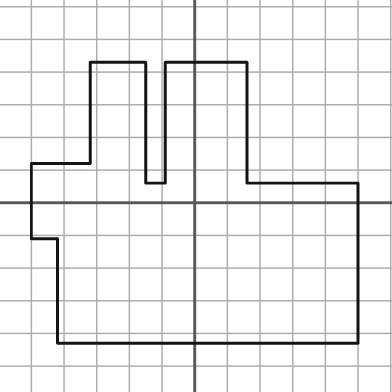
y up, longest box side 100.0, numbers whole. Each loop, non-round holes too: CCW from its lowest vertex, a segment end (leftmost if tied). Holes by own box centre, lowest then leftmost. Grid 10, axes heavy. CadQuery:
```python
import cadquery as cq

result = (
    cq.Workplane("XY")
    .moveTo(-42.0, -43.0)
    .lineTo(50.0, -43.0)
    .lineTo(50.0, 6.0)
    .lineTo(16.0, 6.0)
    .lineTo(16.0, 43.0)
    .lineTo(-9.0, 43.0)
    .lineTo(-9.0, 6.0)
    .lineTo(-15.0, 6.0)
    .lineTo(-15.0, 43.0)
    .lineTo(-32.0, 43.0)
    .lineTo(-32.0, 12.0)
    .lineTo(-50.0, 12.0)
    .lineTo(-50.0, -11.0)
    .lineTo(-42.0, -11.0)
    .close()
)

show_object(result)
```